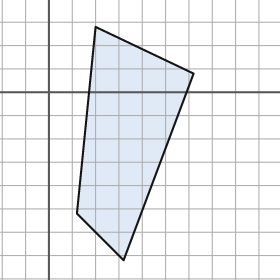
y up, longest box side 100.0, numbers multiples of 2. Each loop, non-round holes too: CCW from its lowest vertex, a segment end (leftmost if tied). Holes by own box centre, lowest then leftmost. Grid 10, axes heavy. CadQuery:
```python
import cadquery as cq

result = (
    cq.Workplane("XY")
    .moveTo(32.0, -72.0)
    .lineTo(62.0, 8.0)
    .lineTo(20.0, 28.0)
    .lineTo(12.0, -52.0)
    .close()
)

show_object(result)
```